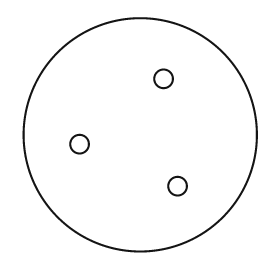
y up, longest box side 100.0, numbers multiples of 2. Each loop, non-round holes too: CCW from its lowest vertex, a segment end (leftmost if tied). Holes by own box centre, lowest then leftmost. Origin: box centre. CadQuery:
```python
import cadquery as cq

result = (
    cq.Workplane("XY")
    .moveTo(0.0, 0.0)
    .circle(50.0)
    .moveTo(16.0, -22.0)
    .circle(4.0)
    .moveTo(-26.0, -4.0)
    .circle(4.0)
    .moveTo(10.0, 24.0)
    .circle(4.0)
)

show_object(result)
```